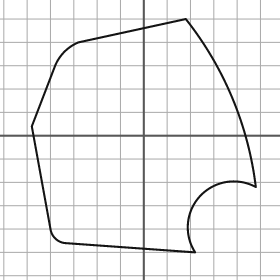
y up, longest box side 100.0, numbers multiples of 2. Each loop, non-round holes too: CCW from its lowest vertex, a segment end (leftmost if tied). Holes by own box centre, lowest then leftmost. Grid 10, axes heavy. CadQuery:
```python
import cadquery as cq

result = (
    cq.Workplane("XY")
    .moveTo(22.0, -50.0)
    .threePointArc((24.0, -26.0), (48.0, -22.0))
    .threePointArc((38.0, 16.0), (18.0, 50.0))
    .lineTo(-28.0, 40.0)
    .threePointArc((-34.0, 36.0), (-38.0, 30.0))
    .lineTo(-48.0, 4.0)
    .lineTo(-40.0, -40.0)
    .threePointArc((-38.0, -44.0), (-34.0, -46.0))
    .close()
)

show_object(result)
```